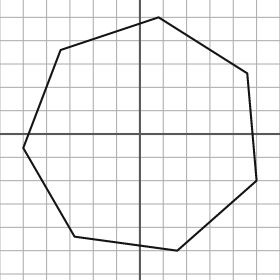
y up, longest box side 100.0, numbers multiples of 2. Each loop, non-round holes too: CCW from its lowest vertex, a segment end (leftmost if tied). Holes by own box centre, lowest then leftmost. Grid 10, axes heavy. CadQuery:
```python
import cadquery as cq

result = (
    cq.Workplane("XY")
    .moveTo(16.0, -50.0)
    .lineTo(50.0, -20.0)
    .lineTo(46.0, 26.0)
    .lineTo(8.0, 50.0)
    .lineTo(-34.0, 36.0)
    .lineTo(-50.0, -6.0)
    .lineTo(-28.0, -44.0)
    .close()
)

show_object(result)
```